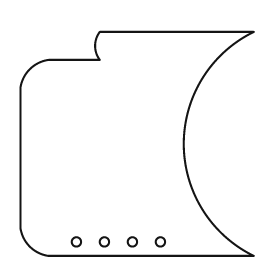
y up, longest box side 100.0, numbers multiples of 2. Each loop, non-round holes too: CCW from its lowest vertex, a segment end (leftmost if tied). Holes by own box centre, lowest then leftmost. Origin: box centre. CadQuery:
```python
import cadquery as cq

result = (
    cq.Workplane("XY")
    .moveTo(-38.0, -48.0)
    .lineTo(50.0, -48.0)
    .threePointArc((20.0, 0.0), (50.0, 48.0))
    .lineTo(-16.0, 48.0)
    .threePointArc((-18.0, 42.0), (-16.0, 36.0))
    .lineTo(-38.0, 36.0)
    .threePointArc((-46.0, 32.0), (-50.0, 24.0))
    .lineTo(-50.0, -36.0)
    .threePointArc((-46.0, -44.0), (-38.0, -48.0))
    .close()
    .moveTo(-26.0, -42.0)
    .circle(2.0)
    .moveTo(-14.0, -42.0)
    .circle(2.0)
    .moveTo(-2.0, -42.0)
    .circle(2.0)
    .moveTo(10.0, -42.0)
    .circle(2.0)
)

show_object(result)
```